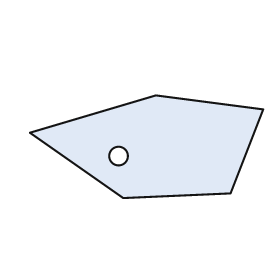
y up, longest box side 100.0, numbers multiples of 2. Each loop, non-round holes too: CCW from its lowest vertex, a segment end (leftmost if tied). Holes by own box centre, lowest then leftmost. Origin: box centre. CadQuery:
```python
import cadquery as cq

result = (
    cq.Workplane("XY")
    .moveTo(-10.0, -22.0)
    .lineTo(36.0, -20.0)
    .lineTo(50.0, 16.0)
    .lineTo(4.0, 22.0)
    .lineTo(-50.0, 6.0)
    .close()
    .moveTo(-12.0, -4.0)
    .circle(4.0)
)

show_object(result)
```